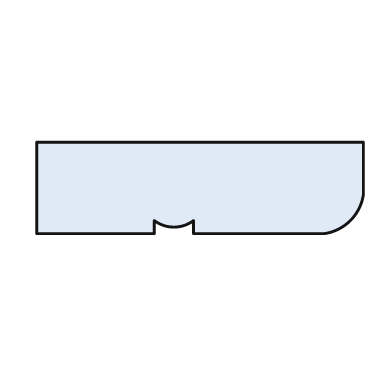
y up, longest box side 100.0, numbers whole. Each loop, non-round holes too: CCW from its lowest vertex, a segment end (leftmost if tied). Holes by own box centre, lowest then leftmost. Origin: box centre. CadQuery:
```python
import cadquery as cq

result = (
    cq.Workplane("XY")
    .moveTo(-50.0, -14.0)
    .lineTo(-14.0, -14.0)
    .lineTo(-14.0, -10.0)
    .threePointArc((-8.0, -12.0), (-2.0, -10.0))
    .lineTo(-2.0, -14.0)
    .lineTo(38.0, -14.0)
    .threePointArc((46.0, -10.0), (50.0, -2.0))
    .lineTo(50.0, 14.0)
    .lineTo(-50.0, 14.0)
    .close()
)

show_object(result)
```